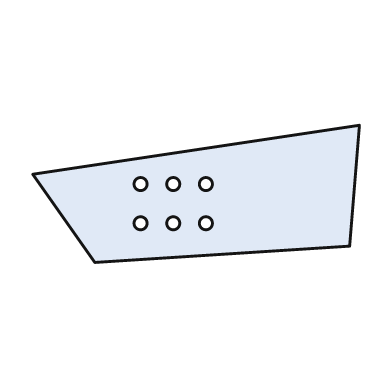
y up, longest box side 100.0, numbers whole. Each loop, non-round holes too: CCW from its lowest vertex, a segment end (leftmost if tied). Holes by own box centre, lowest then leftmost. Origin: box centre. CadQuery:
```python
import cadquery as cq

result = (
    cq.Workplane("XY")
    .moveTo(-31.0, -21.0)
    .lineTo(47.0, -16.0)
    .lineTo(50.0, 21.0)
    .lineTo(-50.0, 6.0)
    .close()
    .moveTo(-17.0, -9.0)
    .circle(2.0)
    .moveTo(-7.0, -9.0)
    .circle(2.0)
    .moveTo(3.0, -9.0)
    .circle(2.0)
    .moveTo(-17.0, 3.0)
    .circle(2.0)
    .moveTo(-7.0, 3.0)
    .circle(2.0)
    .moveTo(3.0, 3.0)
    .circle(2.0)
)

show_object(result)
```